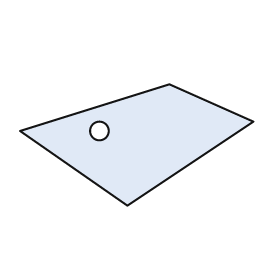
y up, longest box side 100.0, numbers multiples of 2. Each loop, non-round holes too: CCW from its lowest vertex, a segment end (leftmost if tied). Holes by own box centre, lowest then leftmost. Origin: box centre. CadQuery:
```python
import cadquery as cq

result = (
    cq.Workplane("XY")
    .moveTo(-4.0, -26.0)
    .lineTo(50.0, 10.0)
    .lineTo(14.0, 26.0)
    .lineTo(-50.0, 6.0)
    .close()
    .moveTo(-16.0, 6.0)
    .circle(4.0)
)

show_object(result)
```